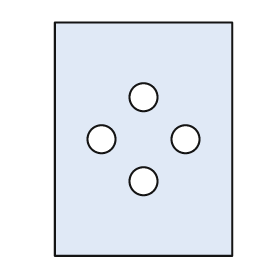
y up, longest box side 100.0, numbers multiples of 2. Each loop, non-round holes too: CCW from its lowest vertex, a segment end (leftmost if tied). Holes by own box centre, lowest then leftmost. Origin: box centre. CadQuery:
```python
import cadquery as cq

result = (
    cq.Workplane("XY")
    .moveTo(-38.0, -50.0)
    .lineTo(38.0, -50.0)
    .lineTo(38.0, 50.0)
    .lineTo(-38.0, 50.0)
    .close()
    .moveTo(0.0, -18.0)
    .circle(6.0)
    .moveTo(-18.0, 0.0)
    .circle(6.0)
    .moveTo(18.0, 0.0)
    .circle(6.0)
    .moveTo(0.0, 18.0)
    .circle(6.0)
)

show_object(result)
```